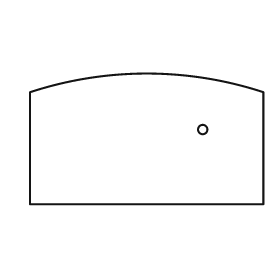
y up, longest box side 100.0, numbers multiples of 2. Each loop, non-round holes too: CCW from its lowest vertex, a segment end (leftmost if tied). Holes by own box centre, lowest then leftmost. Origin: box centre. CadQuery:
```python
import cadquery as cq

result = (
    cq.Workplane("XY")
    .moveTo(-50.0, -28.0)
    .lineTo(50.0, -28.0)
    .lineTo(50.0, 20.0)
    .threePointArc((0.0, 28.0), (-50.0, 20.0))
    .close()
    .moveTo(24.0, 4.0)
    .circle(2.0)
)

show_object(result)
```